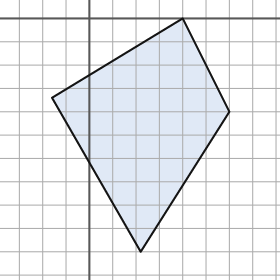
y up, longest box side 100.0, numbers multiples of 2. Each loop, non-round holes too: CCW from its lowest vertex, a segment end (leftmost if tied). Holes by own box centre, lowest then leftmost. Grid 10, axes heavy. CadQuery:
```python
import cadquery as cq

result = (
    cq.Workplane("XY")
    .moveTo(22.0, -100.0)
    .lineTo(60.0, -40.0)
    .lineTo(40.0, 0.0)
    .lineTo(-16.0, -34.0)
    .close()
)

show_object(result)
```